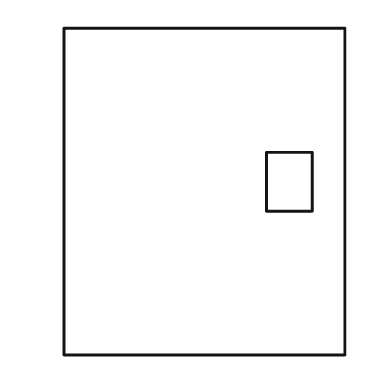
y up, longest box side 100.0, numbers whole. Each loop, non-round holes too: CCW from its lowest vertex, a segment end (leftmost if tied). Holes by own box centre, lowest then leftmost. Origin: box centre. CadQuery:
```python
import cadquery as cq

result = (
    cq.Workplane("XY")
    .moveTo(-43.0, -50.0)
    .lineTo(43.0, -50.0)
    .lineTo(43.0, 50.0)
    .lineTo(-43.0, 50.0)
    .close()
    .moveTo(19.0, -6.0)
    .lineTo(33.0, -6.0)
    .lineTo(33.0, 12.0)
    .lineTo(19.0, 12.0)
    .close()
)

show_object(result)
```